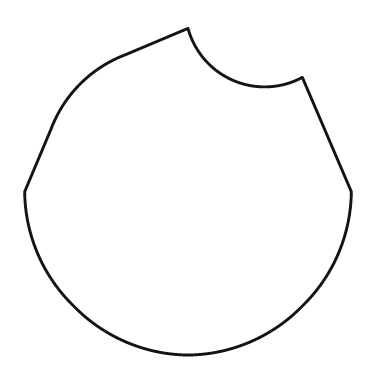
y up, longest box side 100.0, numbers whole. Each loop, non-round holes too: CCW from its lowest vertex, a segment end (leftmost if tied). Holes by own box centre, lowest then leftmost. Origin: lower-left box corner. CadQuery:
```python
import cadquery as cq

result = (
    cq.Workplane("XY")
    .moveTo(50.0, 0.0)
    .threePointArc((69.0, 4.0), (85.0, 15.0))
    .threePointArc((96.0, 31.0), (100.0, 50.0))
    .lineTo(85.0, 85.0)
    .threePointArc((64.0, 84.0), (50.0, 100.0))
    .lineTo(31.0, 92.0)
    .threePointArc((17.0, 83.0), (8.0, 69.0))
    .lineTo(0.0, 50.0)
    .threePointArc((4.0, 31.0), (15.0, 15.0))
    .threePointArc((31.0, 4.0), (50.0, 0.0))
    .close()
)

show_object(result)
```